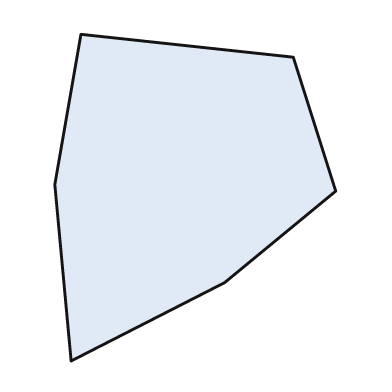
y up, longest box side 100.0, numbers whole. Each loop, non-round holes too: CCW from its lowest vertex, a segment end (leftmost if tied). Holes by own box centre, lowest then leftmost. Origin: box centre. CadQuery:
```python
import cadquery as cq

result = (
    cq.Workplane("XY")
    .moveTo(-38.0, -50.0)
    .lineTo(9.0, -26.0)
    .lineTo(43.0, 2.0)
    .lineTo(30.0, 43.0)
    .lineTo(-35.0, 50.0)
    .lineTo(-43.0, 4.0)
    .close()
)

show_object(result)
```